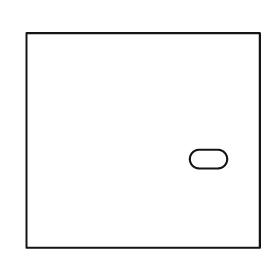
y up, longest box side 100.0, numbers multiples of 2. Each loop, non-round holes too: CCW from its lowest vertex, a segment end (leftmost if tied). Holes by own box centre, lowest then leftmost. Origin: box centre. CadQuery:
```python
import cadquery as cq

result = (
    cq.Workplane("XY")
    .moveTo(-50.0, -46.0)
    .lineTo(50.0, -46.0)
    .lineTo(50.0, 46.0)
    .lineTo(-50.0, 46.0)
    .close()
    .moveTo(24.0, -12.0)
    .lineTo(32.0, -12.0)
    .threePointArc((36.0, -8.0), (32.0, -4.0))
    .lineTo(24.0, -4.0)
    .threePointArc((20.0, -8.0), (24.0, -12.0))
    .close()
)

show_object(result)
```